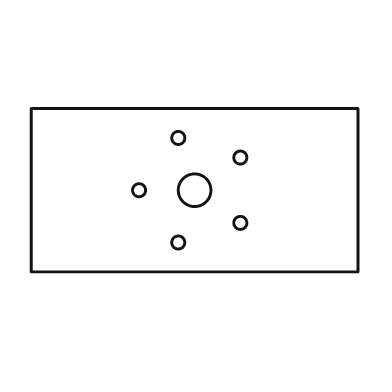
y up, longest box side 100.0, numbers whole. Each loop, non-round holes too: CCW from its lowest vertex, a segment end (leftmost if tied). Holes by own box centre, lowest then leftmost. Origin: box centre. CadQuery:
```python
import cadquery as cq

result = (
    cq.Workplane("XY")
    .moveTo(-50.0, -25.0)
    .lineTo(50.0, -25.0)
    .lineTo(50.0, 25.0)
    .lineTo(-50.0, 25.0)
    .close()
    .moveTo(-5.0, -16.0)
    .circle(2.0)
    .moveTo(14.0, -10.0)
    .circle(2.0)
    .moveTo(-17.0, 0.0)
    .circle(2.0)
    .moveTo(0.0, 0.0)
    .circle(5.0)
    .moveTo(14.0, 10.0)
    .circle(2.0)
    .moveTo(-5.0, 16.0)
    .circle(2.0)
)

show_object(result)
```